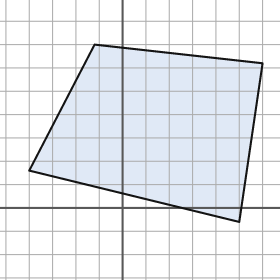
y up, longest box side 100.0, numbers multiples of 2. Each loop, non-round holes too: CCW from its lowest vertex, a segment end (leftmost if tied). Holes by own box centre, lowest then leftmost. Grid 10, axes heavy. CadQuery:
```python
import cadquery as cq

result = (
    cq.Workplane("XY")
    .moveTo(50.0, -6.0)
    .lineTo(60.0, 62.0)
    .lineTo(-12.0, 70.0)
    .lineTo(-40.0, 16.0)
    .close()
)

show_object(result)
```